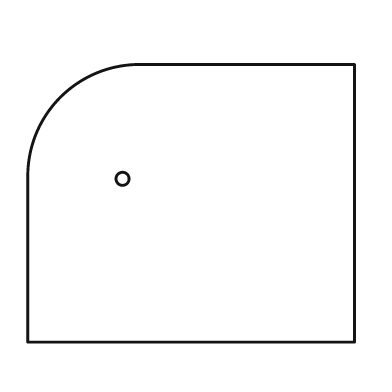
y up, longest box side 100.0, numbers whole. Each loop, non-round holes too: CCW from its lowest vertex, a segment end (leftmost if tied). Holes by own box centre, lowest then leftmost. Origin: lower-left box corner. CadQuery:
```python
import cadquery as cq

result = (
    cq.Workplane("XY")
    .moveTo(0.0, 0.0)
    .lineTo(100.0, 0.0)
    .lineTo(100.0, 85.0)
    .lineTo(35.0, 85.0)
    .threePointArc((10.0, 75.0), (0.0, 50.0))
    .close()
    .moveTo(29.0, 50.0)
    .circle(2.0)
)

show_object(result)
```